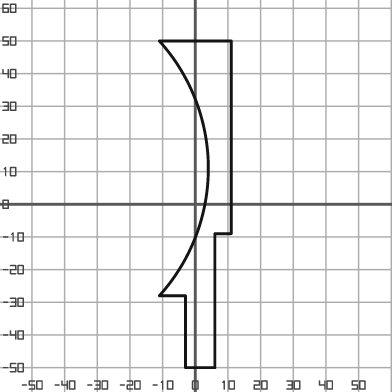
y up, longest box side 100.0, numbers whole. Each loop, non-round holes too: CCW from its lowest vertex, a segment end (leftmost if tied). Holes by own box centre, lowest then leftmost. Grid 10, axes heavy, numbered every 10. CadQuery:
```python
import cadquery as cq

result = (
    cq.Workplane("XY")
    .moveTo(-3.0, -50.0)
    .lineTo(6.0, -50.0)
    .lineTo(6.0, -9.0)
    .lineTo(11.0, -9.0)
    .lineTo(11.0, 50.0)
    .lineTo(-11.0, 50.0)
    .threePointArc((4.0, 11.0), (-11.0, -28.0))
    .lineTo(-3.0, -28.0)
    .close()
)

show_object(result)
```